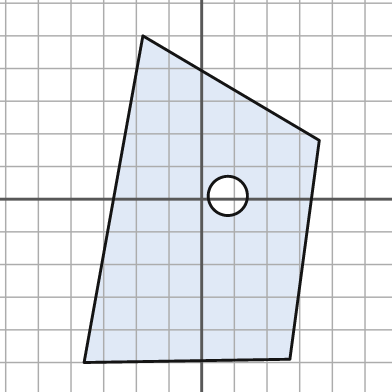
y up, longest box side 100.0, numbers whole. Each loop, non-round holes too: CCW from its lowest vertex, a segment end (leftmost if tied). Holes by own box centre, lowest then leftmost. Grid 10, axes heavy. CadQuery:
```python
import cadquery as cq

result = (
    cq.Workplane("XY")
    .moveTo(-36.0, -50.0)
    .lineTo(27.0, -49.0)
    .lineTo(36.0, 18.0)
    .lineTo(-18.0, 50.0)
    .close()
    .moveTo(8.0, 1.0)
    .circle(6.0)
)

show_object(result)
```